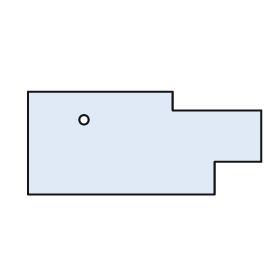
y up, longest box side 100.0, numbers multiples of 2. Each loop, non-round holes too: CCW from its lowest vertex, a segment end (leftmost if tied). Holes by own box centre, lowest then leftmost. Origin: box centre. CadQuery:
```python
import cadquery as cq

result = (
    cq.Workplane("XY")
    .moveTo(-50.0, -22.0)
    .lineTo(30.0, -22.0)
    .lineTo(30.0, -8.0)
    .lineTo(50.0, -8.0)
    .lineTo(50.0, 14.0)
    .lineTo(12.0, 14.0)
    .lineTo(12.0, 22.0)
    .lineTo(-50.0, 22.0)
    .close()
    .moveTo(-26.0, 10.0)
    .circle(2.0)
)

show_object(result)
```